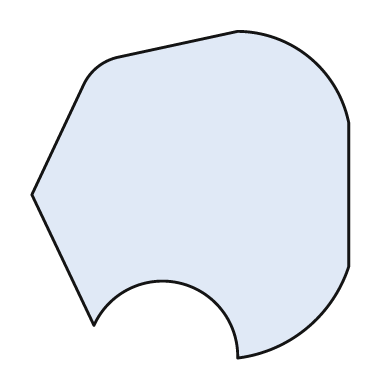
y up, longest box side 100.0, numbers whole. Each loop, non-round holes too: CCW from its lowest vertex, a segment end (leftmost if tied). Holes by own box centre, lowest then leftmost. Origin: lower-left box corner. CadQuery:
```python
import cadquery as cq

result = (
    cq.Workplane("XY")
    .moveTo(63.0, 0.0)
    .threePointArc((84.0, 9.0), (97.0, 28.0))
    .lineTo(97.0, 72.0)
    .threePointArc((85.0, 92.0), (63.0, 100.0))
    .lineTo(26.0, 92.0)
    .threePointArc((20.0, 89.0), (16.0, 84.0))
    .lineTo(0.0, 50.0)
    .lineTo(19.0, 10.0)
    .threePointArc((45.0, 23.0), (63.0, 0.0))
    .close()
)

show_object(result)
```